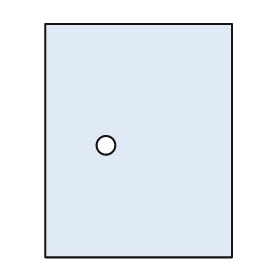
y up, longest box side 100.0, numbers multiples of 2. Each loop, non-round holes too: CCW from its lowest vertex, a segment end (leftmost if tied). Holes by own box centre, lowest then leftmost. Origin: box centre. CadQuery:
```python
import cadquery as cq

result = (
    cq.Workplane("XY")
    .moveTo(-40.0, -50.0)
    .lineTo(40.0, -50.0)
    .lineTo(40.0, 50.0)
    .lineTo(-40.0, 50.0)
    .close()
    .moveTo(-14.0, -2.0)
    .circle(4.0)
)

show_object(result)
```